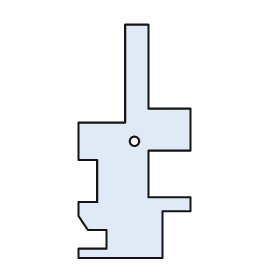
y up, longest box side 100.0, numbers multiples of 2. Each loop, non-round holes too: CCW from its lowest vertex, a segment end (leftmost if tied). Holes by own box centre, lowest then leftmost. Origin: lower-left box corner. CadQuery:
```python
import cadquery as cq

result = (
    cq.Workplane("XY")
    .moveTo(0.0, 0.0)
    .lineTo(36.0, 0.0)
    .lineTo(36.0, 20.0)
    .lineTo(48.0, 20.0)
    .lineTo(48.0, 26.0)
    .lineTo(30.0, 26.0)
    .lineTo(30.0, 46.0)
    .lineTo(48.0, 46.0)
    .lineTo(48.0, 64.0)
    .lineTo(30.0, 64.0)
    .lineTo(30.0, 100.0)
    .lineTo(20.0, 100.0)
    .lineTo(20.0, 58.0)
    .lineTo(0.0, 58.0)
    .lineTo(0.0, 42.0)
    .lineTo(8.0, 42.0)
    .lineTo(8.0, 24.0)
    .lineTo(0.0, 24.0)
    .lineTo(0.0, 18.0)
    .lineTo(4.0, 12.0)
    .lineTo(12.0, 12.0)
    .lineTo(12.0, 4.0)
    .lineTo(0.0, 4.0)
    .close()
    .moveTo(24.0, 50.0)
    .circle(2.0)
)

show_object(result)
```